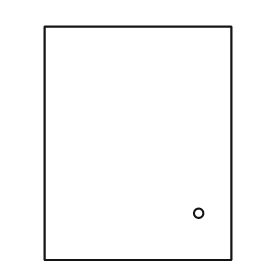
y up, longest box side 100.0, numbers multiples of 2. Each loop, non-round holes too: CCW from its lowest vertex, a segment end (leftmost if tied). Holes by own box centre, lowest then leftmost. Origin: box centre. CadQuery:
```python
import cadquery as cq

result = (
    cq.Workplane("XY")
    .moveTo(-40.0, -50.0)
    .lineTo(40.0, -50.0)
    .lineTo(40.0, 50.0)
    .lineTo(-40.0, 50.0)
    .close()
    .moveTo(26.0, -30.0)
    .circle(2.0)
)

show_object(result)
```